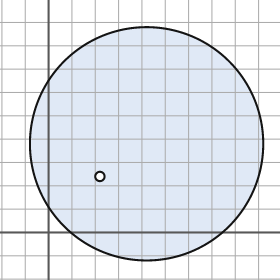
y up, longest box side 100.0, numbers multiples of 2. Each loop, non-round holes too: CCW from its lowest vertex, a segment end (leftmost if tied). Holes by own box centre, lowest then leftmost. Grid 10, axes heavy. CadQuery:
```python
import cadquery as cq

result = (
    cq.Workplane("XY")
    .moveTo(42.0, 38.0)
    .circle(50.0)
    .moveTo(22.0, 24.0)
    .circle(2.0)
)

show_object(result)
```